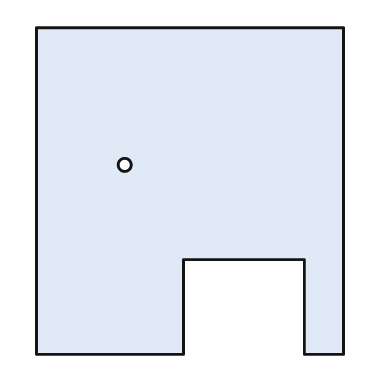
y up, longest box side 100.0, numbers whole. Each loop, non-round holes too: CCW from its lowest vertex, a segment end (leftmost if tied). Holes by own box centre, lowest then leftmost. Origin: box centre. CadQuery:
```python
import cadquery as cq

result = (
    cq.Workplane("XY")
    .moveTo(-47.0, -50.0)
    .lineTo(-2.0, -50.0)
    .lineTo(-2.0, -21.0)
    .lineTo(35.0, -21.0)
    .lineTo(35.0, -50.0)
    .lineTo(47.0, -50.0)
    .lineTo(47.0, 50.0)
    .lineTo(-47.0, 50.0)
    .close()
    .moveTo(-20.0, 8.0)
    .circle(2.0)
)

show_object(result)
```